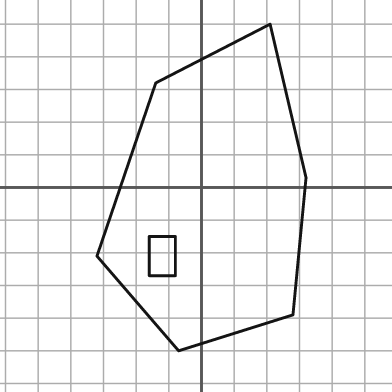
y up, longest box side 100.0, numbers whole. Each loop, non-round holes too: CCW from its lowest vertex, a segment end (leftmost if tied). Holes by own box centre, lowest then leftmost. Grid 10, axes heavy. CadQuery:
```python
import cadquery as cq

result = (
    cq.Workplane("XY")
    .moveTo(-7.0, -50.0)
    .lineTo(28.0, -39.0)
    .lineTo(32.0, 3.0)
    .lineTo(21.0, 50.0)
    .lineTo(-14.0, 32.0)
    .lineTo(-32.0, -21.0)
    .close()
    .moveTo(-16.0, -27.0)
    .lineTo(-8.0, -27.0)
    .lineTo(-8.0, -15.0)
    .lineTo(-16.0, -15.0)
    .close()
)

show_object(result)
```